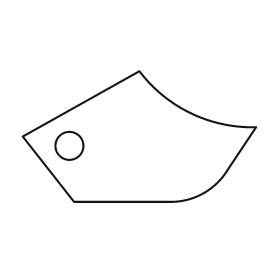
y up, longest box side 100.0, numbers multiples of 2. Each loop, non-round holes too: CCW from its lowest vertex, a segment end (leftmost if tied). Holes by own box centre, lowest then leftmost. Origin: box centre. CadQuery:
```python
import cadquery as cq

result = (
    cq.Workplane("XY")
    .moveTo(-28.0, -28.0)
    .lineTo(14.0, -28.0)
    .threePointArc((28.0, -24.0), (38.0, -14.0))
    .lineTo(50.0, 4.0)
    .threePointArc((22.0, 10.0), (0.0, 28.0))
    .lineTo(-50.0, 0.0)
    .close()
    .moveTo(-30.0, -4.0)
    .circle(6.0)
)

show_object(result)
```